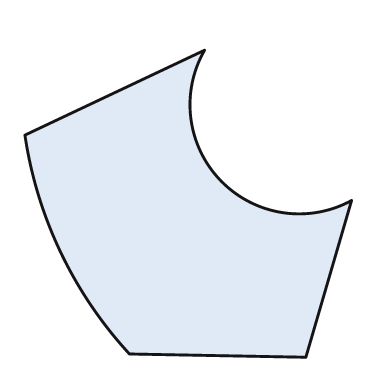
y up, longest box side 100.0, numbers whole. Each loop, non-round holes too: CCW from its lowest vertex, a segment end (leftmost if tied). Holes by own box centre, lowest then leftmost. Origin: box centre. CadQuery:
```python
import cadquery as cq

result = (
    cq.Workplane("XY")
    .moveTo(36.0, -47.0)
    .lineTo(50.0, 1.0)
    .threePointArc((10.0, 7.0), (5.0, 47.0))
    .lineTo(-50.0, 21.0)
    .threePointArc((-39.0, -15.0), (-18.0, -46.0))
    .close()
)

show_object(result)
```